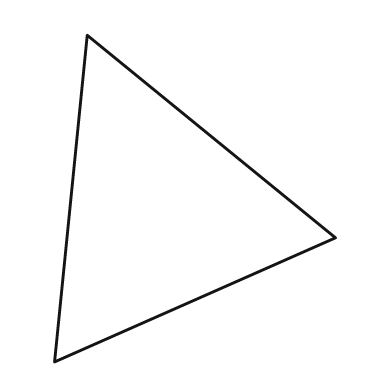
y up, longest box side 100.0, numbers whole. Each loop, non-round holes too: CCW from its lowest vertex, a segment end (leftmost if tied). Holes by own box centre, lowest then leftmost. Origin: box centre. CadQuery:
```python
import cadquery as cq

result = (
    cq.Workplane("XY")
    .moveTo(-43.0, -50.0)
    .lineTo(43.0, -12.0)
    .lineTo(-33.0, 50.0)
    .close()
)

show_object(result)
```